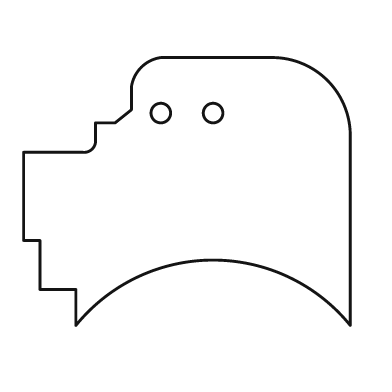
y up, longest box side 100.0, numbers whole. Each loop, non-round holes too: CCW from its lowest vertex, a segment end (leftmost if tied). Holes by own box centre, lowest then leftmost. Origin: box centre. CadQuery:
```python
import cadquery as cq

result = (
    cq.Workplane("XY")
    .moveTo(-34.0, -41.0)
    .threePointArc((8.0, -21.0), (50.0, -41.0))
    .lineTo(50.0, 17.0)
    .threePointArc((43.0, 34.0), (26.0, 41.0))
    .lineTo(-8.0, 41.0)
    .threePointArc((-14.0, 38.0), (-17.0, 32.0))
    .lineTo(-17.0, 25.0)
    .lineTo(-22.0, 21.0)
    .lineTo(-28.0, 21.0)
    .lineTo(-28.0, 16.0)
    .threePointArc((-29.0, 13.0), (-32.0, 12.0))
    .lineTo(-50.0, 12.0)
    .lineTo(-50.0, -15.0)
    .lineTo(-45.0, -15.0)
    .lineTo(-45.0, -30.0)
    .lineTo(-34.0, -30.0)
    .close()
    .moveTo(-8.0, 24.0)
    .circle(3.0)
    .moveTo(8.0, 24.0)
    .circle(3.0)
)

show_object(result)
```